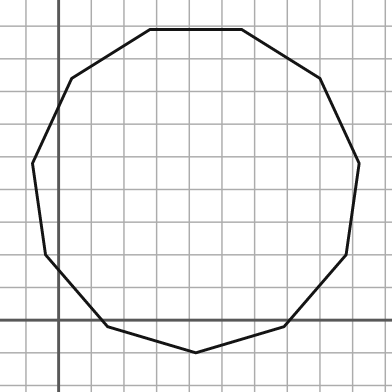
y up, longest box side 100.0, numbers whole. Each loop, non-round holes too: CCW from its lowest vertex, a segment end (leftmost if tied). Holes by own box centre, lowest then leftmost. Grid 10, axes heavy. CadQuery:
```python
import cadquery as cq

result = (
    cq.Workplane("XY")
    .moveTo(42.0, -10.0)
    .lineTo(69.0, -2.0)
    .lineTo(88.0, 20.0)
    .lineTo(92.0, 48.0)
    .lineTo(80.0, 74.0)
    .lineTo(56.0, 89.0)
    .lineTo(28.0, 89.0)
    .lineTo(4.0, 74.0)
    .lineTo(-8.0, 48.0)
    .lineTo(-4.0, 20.0)
    .lineTo(15.0, -2.0)
    .close()
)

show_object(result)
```